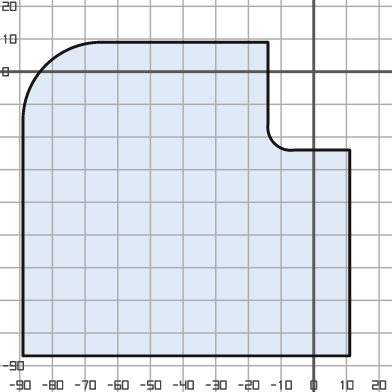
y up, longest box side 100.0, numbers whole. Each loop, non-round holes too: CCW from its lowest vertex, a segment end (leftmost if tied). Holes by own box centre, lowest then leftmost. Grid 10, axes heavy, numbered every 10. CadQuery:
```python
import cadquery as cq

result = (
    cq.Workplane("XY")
    .moveTo(-89.0, -87.0)
    .lineTo(11.0, -87.0)
    .lineTo(11.0, -24.0)
    .lineTo(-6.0, -24.0)
    .threePointArc((-12.0, -22.0), (-14.0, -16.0))
    .lineTo(-14.0, 9.0)
    .lineTo(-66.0, 9.0)
    .threePointArc((-82.0, 2.0), (-89.0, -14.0))
    .close()
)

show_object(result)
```